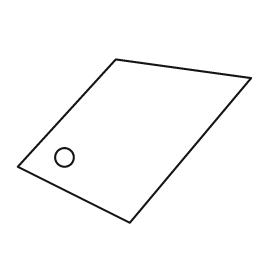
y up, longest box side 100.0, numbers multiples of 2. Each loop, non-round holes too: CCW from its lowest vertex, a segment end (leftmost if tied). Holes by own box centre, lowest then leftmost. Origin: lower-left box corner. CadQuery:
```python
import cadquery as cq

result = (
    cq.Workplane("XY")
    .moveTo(48.0, 0.0)
    .lineTo(100.0, 62.0)
    .lineTo(42.0, 70.0)
    .lineTo(0.0, 24.0)
    .close()
    .moveTo(20.0, 28.0)
    .circle(4.0)
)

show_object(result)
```